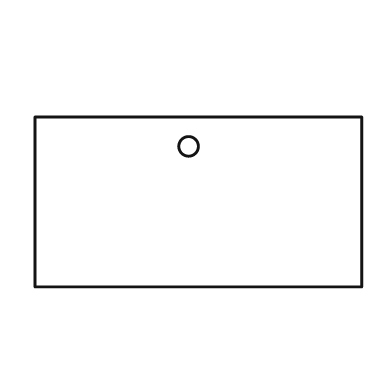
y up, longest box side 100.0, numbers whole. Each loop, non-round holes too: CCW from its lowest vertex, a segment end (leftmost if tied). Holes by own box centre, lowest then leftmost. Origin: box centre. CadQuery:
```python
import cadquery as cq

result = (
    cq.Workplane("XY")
    .moveTo(-50.0, -26.0)
    .lineTo(50.0, -26.0)
    .lineTo(50.0, 26.0)
    .lineTo(-50.0, 26.0)
    .close()
    .moveTo(-3.0, 17.0)
    .circle(3.0)
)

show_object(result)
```